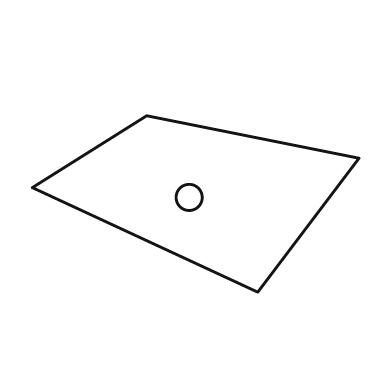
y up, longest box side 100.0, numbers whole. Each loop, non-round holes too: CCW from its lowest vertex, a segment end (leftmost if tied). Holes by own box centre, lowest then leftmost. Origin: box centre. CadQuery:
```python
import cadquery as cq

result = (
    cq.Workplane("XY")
    .moveTo(19.0, -27.0)
    .lineTo(50.0, 14.0)
    .lineTo(-15.0, 27.0)
    .lineTo(-50.0, 5.0)
    .close()
    .moveTo(-2.0, 2.0)
    .circle(4.0)
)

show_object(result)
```